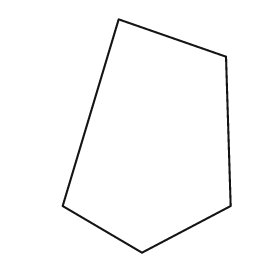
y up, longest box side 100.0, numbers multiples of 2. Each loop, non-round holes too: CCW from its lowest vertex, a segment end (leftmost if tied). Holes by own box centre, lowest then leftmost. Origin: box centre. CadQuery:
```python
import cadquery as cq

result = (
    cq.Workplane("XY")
    .moveTo(-2.0, -50.0)
    .lineTo(36.0, -30.0)
    .lineTo(34.0, 34.0)
    .lineTo(-12.0, 50.0)
    .lineTo(-36.0, -30.0)
    .close()
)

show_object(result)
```